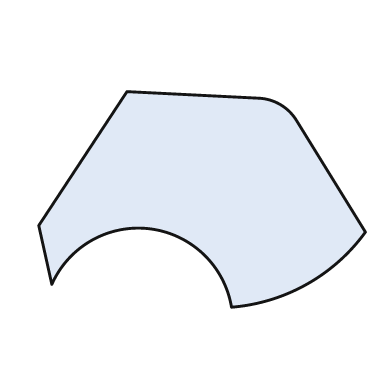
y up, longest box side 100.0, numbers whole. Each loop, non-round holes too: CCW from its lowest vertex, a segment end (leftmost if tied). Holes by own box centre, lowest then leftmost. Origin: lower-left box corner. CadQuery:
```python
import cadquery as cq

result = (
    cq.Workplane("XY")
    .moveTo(59.0, 0.0)
    .threePointArc((82.0, 7.0), (100.0, 23.0))
    .lineTo(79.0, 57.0)
    .threePointArc((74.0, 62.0), (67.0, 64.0))
    .lineTo(27.0, 66.0)
    .lineTo(0.0, 25.0)
    .lineTo(4.0, 7.0)
    .threePointArc((34.0, 24.0), (59.0, 0.0))
    .close()
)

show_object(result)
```